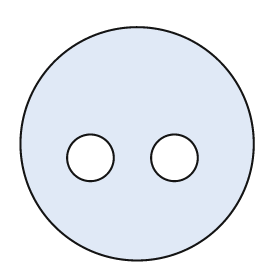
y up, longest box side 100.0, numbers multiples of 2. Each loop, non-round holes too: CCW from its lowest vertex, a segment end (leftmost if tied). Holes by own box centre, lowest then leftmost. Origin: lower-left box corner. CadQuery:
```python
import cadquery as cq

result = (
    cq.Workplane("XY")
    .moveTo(50.0, 50.0)
    .circle(50.0)
    .moveTo(30.0, 44.0)
    .circle(10.0)
    .moveTo(66.0, 44.0)
    .circle(10.0)
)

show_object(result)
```